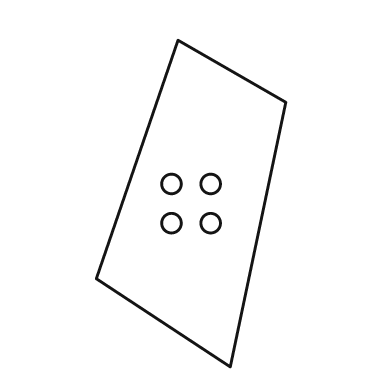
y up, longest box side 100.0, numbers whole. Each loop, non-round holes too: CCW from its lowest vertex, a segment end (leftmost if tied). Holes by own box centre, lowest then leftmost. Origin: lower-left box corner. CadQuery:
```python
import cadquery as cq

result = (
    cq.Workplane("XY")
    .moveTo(41.0, 0.0)
    .lineTo(58.0, 81.0)
    .lineTo(25.0, 100.0)
    .lineTo(0.0, 27.0)
    .close()
    .moveTo(23.0, 44.0)
    .circle(3.0)
    .moveTo(35.0, 44.0)
    .circle(3.0)
    .moveTo(23.0, 56.0)
    .circle(3.0)
    .moveTo(35.0, 56.0)
    .circle(3.0)
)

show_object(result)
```